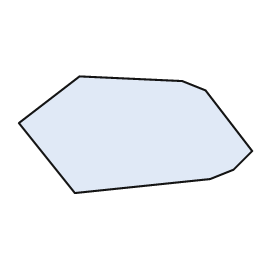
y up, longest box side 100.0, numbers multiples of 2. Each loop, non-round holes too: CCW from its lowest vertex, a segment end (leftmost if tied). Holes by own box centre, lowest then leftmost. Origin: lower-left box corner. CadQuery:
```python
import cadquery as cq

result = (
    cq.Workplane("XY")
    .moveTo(24.0, 0.0)
    .lineTo(82.0, 6.0)
    .lineTo(92.0, 10.0)
    .lineTo(100.0, 18.0)
    .lineTo(80.0, 44.0)
    .lineTo(70.0, 48.0)
    .lineTo(26.0, 50.0)
    .lineTo(0.0, 30.0)
    .close()
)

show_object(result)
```